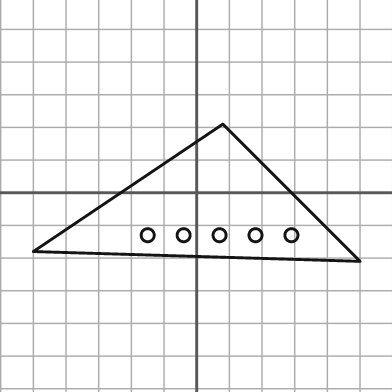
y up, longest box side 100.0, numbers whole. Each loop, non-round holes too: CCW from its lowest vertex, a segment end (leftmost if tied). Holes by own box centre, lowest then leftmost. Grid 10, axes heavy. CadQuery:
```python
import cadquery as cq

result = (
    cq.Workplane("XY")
    .moveTo(50.0, -21.0)
    .lineTo(8.0, 21.0)
    .lineTo(-50.0, -18.0)
    .close()
    .moveTo(-15.0, -13.0)
    .circle(2.0)
    .moveTo(-4.0, -13.0)
    .circle(2.0)
    .moveTo(7.0, -13.0)
    .circle(2.0)
    .moveTo(18.0, -13.0)
    .circle(2.0)
    .moveTo(29.0, -13.0)
    .circle(2.0)
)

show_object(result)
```